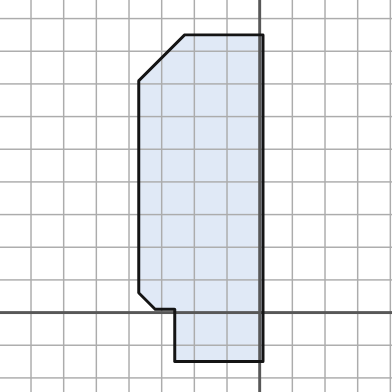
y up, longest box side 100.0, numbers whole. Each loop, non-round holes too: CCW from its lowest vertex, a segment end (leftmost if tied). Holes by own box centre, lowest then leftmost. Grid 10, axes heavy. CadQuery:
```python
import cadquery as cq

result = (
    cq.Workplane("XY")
    .moveTo(-26.0, -15.0)
    .lineTo(1.0, -15.0)
    .lineTo(1.0, 85.0)
    .lineTo(-23.0, 85.0)
    .lineTo(-37.0, 71.0)
    .lineTo(-37.0, 6.0)
    .lineTo(-32.0, 1.0)
    .lineTo(-26.0, 1.0)
    .close()
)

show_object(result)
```